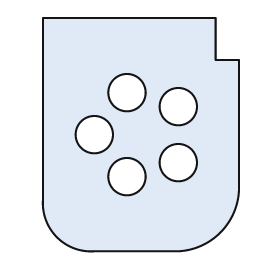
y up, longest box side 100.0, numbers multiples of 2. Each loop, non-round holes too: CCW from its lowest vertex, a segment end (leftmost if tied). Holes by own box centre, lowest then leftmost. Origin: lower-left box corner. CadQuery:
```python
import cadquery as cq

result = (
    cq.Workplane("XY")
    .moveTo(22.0, 0.0)
    .lineTo(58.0, 0.0)
    .threePointArc((76.0, 8.0), (84.0, 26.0))
    .lineTo(84.0, 82.0)
    .lineTo(74.0, 82.0)
    .lineTo(74.0, 100.0)
    .lineTo(0.0, 100.0)
    .lineTo(0.0, 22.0)
    .threePointArc((6.0, 6.0), (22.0, 0.0))
    .close()
    .moveTo(36.0, 32.0)
    .circle(8.0)
    .moveTo(58.0, 38.0)
    .circle(8.0)
    .moveTo(22.0, 50.0)
    .circle(8.0)
    .moveTo(58.0, 62.0)
    .circle(8.0)
    .moveTo(36.0, 68.0)
    .circle(8.0)
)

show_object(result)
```